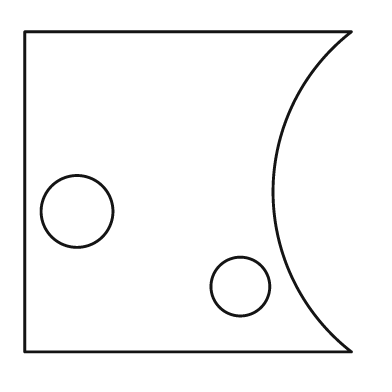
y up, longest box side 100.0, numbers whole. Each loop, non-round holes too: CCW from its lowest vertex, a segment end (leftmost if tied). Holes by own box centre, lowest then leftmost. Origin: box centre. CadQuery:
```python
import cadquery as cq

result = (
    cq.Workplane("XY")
    .moveTo(-50.0, -49.0)
    .lineTo(50.0, -49.0)
    .threePointArc((26.0, 0.0), (50.0, 49.0))
    .lineTo(-50.0, 49.0)
    .close()
    .moveTo(16.0, -29.0)
    .circle(9.0)
    .moveTo(-34.0, -6.0)
    .circle(11.0)
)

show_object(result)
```